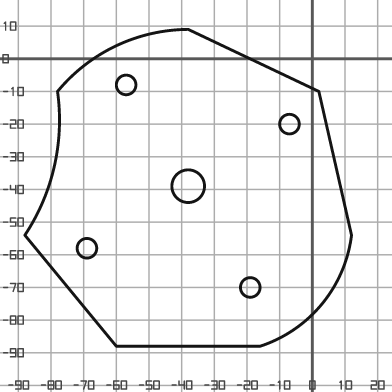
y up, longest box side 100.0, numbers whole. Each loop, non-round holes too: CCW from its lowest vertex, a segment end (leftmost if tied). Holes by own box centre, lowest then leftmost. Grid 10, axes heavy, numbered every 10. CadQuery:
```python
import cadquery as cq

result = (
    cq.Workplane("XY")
    .moveTo(-60.0, -88.0)
    .lineTo(-16.0, -88.0)
    .threePointArc((3.0, -75.0), (12.0, -54.0))
    .lineTo(2.0, -10.0)
    .lineTo(-38.0, 9.0)
    .threePointArc((-60.0, 4.0), (-78.0, -10.0))
    .threePointArc((-79.0, -33.0), (-88.0, -54.0))
    .close()
    .moveTo(-19.0, -70.0)
    .circle(3.0)
    .moveTo(-69.0, -58.0)
    .circle(3.0)
    .moveTo(-38.0, -39.0)
    .circle(5.0)
    .moveTo(-7.0, -20.0)
    .circle(3.0)
    .moveTo(-57.0, -8.0)
    .circle(3.0)
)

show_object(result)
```